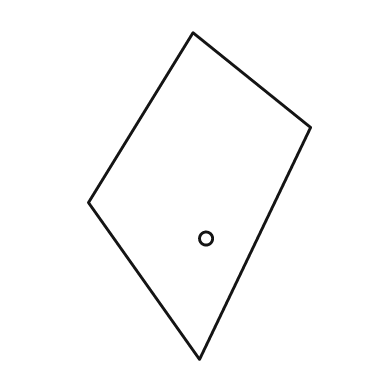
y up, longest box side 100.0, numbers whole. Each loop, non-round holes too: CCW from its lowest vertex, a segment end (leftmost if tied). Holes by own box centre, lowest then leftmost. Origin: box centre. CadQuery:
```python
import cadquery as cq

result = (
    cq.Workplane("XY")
    .moveTo(0.0, -50.0)
    .lineTo(34.0, 21.0)
    .lineTo(-2.0, 50.0)
    .lineTo(-34.0, -2.0)
    .close()
    .moveTo(2.0, -13.0)
    .circle(2.0)
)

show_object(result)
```